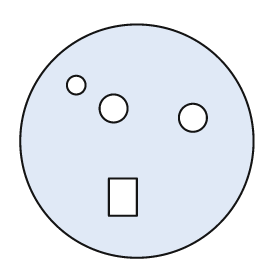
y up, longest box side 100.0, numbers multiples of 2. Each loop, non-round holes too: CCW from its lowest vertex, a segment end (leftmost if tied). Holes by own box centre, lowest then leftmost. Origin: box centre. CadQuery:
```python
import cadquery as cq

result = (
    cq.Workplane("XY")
    .moveTo(0.0, 0.0)
    .circle(50.0)
    .moveTo(-12.0, -32.0)
    .lineTo(0.0, -32.0)
    .lineTo(0.0, -16.0)
    .lineTo(-12.0, -16.0)
    .close()
    .moveTo(24.0, 10.0)
    .circle(6.0)
    .moveTo(-10.0, 14.0)
    .circle(6.0)
    .moveTo(-26.0, 24.0)
    .circle(4.0)
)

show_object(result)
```